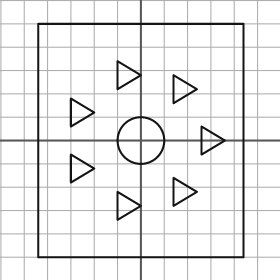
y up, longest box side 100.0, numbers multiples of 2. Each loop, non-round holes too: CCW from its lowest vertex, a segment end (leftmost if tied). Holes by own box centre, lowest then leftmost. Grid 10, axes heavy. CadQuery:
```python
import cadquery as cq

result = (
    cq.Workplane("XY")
    .moveTo(-44.0, -50.0)
    .lineTo(44.0, -50.0)
    .lineTo(44.0, 50.0)
    .lineTo(-44.0, 50.0)
    .close()
    .moveTo(-10.0, -34.0)
    .lineTo(0.0, -28.0)
    .lineTo(-10.0, -22.0)
    .close()
    .moveTo(14.0, -28.0)
    .lineTo(24.0, -22.0)
    .lineTo(14.0, -16.0)
    .close()
    .moveTo(-30.0, -18.0)
    .lineTo(-20.0, -12.0)
    .lineTo(-30.0, -6.0)
    .close()
    .moveTo(0.0, 0.0)
    .circle(10.0)
    .moveTo(26.0, -6.0)
    .lineTo(36.0, 0.0)
    .lineTo(26.0, 6.0)
    .close()
    .moveTo(-30.0, 6.0)
    .lineTo(-20.0, 12.0)
    .lineTo(-30.0, 18.0)
    .close()
    .moveTo(14.0, 16.0)
    .lineTo(24.0, 22.0)
    .lineTo(14.0, 28.0)
    .close()
    .moveTo(-10.0, 22.0)
    .lineTo(0.0, 28.0)
    .lineTo(-10.0, 34.0)
    .close()
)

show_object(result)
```